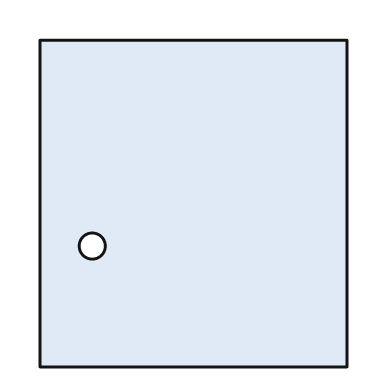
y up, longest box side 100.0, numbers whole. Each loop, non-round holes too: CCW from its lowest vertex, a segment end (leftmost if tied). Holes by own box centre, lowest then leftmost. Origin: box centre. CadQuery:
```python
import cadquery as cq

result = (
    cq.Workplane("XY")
    .moveTo(-47.0, -50.0)
    .lineTo(47.0, -50.0)
    .lineTo(47.0, 50.0)
    .lineTo(-47.0, 50.0)
    .close()
    .moveTo(-31.0, -13.0)
    .circle(4.0)
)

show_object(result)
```